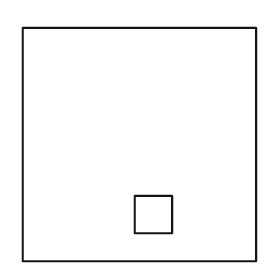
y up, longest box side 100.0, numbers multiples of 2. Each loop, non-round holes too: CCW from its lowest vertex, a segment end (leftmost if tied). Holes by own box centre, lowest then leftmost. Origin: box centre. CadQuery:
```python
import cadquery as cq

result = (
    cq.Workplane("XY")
    .moveTo(-50.0, -50.0)
    .lineTo(50.0, -50.0)
    .lineTo(50.0, 50.0)
    .lineTo(-50.0, 50.0)
    .close()
    .moveTo(-2.0, -38.0)
    .lineTo(14.0, -38.0)
    .lineTo(14.0, -22.0)
    .lineTo(-2.0, -22.0)
    .close()
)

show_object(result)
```